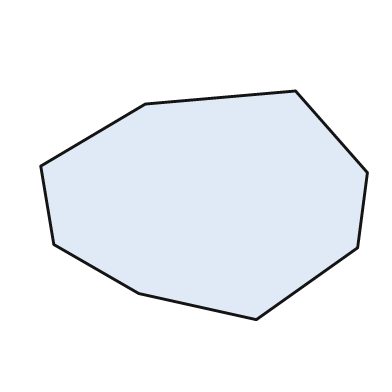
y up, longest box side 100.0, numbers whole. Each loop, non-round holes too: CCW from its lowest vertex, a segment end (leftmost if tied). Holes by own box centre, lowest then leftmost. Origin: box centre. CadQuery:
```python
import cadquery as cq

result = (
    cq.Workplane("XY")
    .moveTo(16.0, -35.0)
    .lineTo(47.0, -13.0)
    .lineTo(50.0, 10.0)
    .lineTo(28.0, 35.0)
    .lineTo(-18.0, 31.0)
    .lineTo(-50.0, 12.0)
    .lineTo(-46.0, -12.0)
    .lineTo(-20.0, -27.0)
    .close()
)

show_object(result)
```